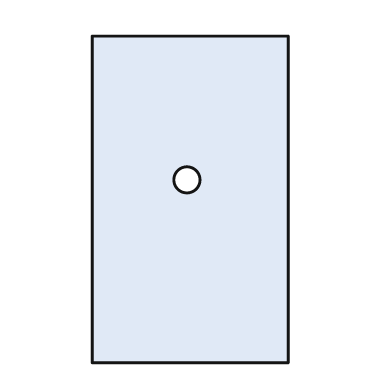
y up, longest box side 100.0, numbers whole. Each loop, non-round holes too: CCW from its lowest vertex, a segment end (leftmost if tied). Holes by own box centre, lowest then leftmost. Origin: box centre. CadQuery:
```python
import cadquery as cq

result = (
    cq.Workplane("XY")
    .moveTo(-30.0, -50.0)
    .lineTo(30.0, -50.0)
    .lineTo(30.0, 50.0)
    .lineTo(-30.0, 50.0)
    .close()
    .moveTo(-1.0, 6.0)
    .circle(4.0)
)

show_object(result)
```